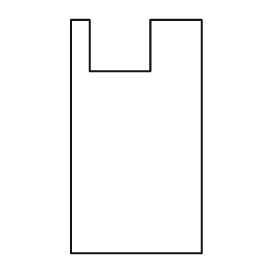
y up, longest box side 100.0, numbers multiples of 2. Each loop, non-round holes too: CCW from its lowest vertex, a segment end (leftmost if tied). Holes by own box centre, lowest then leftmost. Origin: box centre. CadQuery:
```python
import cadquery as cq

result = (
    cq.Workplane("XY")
    .moveTo(-28.0, -50.0)
    .lineTo(28.0, -50.0)
    .lineTo(28.0, 50.0)
    .lineTo(6.0, 50.0)
    .lineTo(6.0, 28.0)
    .lineTo(-20.0, 28.0)
    .lineTo(-20.0, 50.0)
    .lineTo(-28.0, 50.0)
    .close()
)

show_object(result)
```